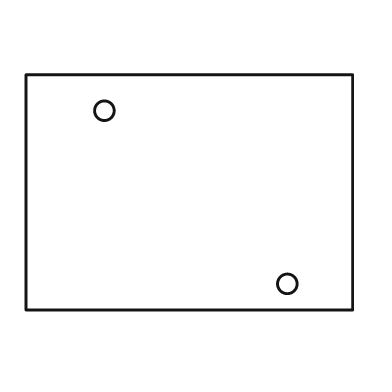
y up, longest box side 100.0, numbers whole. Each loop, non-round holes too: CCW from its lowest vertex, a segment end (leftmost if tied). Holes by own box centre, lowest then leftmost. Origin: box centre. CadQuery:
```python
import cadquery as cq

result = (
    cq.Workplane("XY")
    .moveTo(-50.0, -36.0)
    .lineTo(50.0, -36.0)
    .lineTo(50.0, 36.0)
    .lineTo(-50.0, 36.0)
    .close()
    .moveTo(30.0, -28.0)
    .circle(3.0)
    .moveTo(-26.0, 25.0)
    .circle(3.0)
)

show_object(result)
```